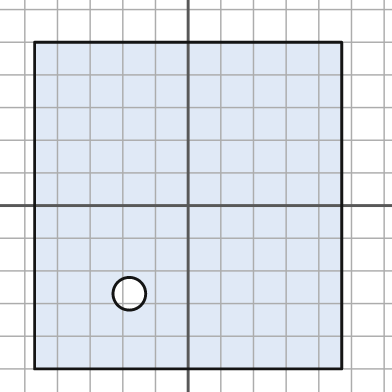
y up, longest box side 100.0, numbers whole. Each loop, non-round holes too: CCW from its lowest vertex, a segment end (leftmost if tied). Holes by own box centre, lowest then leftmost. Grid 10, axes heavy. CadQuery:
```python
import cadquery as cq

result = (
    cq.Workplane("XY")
    .moveTo(-47.0, -50.0)
    .lineTo(47.0, -50.0)
    .lineTo(47.0, 50.0)
    .lineTo(-47.0, 50.0)
    .close()
    .moveTo(-18.0, -27.0)
    .circle(5.0)
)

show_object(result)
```